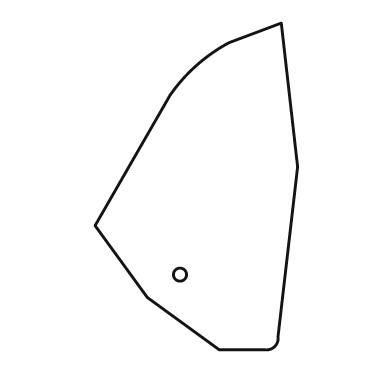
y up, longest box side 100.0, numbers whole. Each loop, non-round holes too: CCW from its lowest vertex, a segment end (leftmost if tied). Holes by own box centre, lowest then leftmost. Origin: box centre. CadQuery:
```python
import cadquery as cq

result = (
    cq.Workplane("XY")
    .moveTo(7.0, -50.0)
    .lineTo(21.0, -50.0)
    .threePointArc((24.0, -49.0), (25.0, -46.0))
    .lineTo(31.0, 6.0)
    .lineTo(26.0, 50.0)
    .lineTo(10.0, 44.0)
    .threePointArc((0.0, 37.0), (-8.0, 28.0))
    .lineTo(-31.0, -12.0)
    .lineTo(-15.0, -34.0)
    .close()
    .moveTo(-5.0, -27.0)
    .circle(2.0)
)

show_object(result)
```